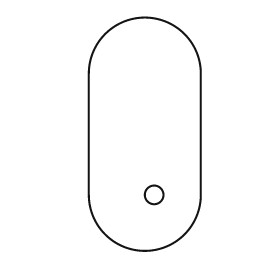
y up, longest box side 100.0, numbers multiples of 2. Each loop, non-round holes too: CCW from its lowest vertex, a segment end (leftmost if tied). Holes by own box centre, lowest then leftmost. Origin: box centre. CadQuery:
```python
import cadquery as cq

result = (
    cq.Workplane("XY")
    .moveTo(-24.0, -26.0)
    .threePointArc((0.0, -50.0), (24.0, -26.0))
    .lineTo(24.0, 26.0)
    .threePointArc((0.0, 50.0), (-24.0, 26.0))
    .close()
    .moveTo(4.0, -26.0)
    .circle(4.0)
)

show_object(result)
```